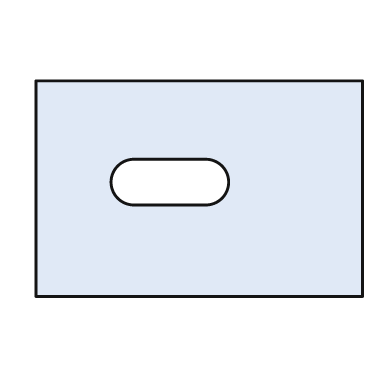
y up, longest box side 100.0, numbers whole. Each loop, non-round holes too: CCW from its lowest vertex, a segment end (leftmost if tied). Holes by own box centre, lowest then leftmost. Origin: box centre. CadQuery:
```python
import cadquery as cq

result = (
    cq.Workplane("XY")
    .moveTo(-50.0, -33.0)
    .lineTo(50.0, -33.0)
    .lineTo(50.0, 33.0)
    .lineTo(-50.0, 33.0)
    .close()
    .moveTo(-20.0, -5.0)
    .lineTo(2.0, -5.0)
    .threePointArc((9.0, 2.0), (2.0, 9.0))
    .lineTo(-20.0, 9.0)
    .threePointArc((-27.0, 2.0), (-20.0, -5.0))
    .close()
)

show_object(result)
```